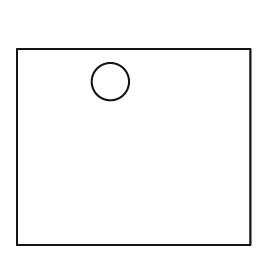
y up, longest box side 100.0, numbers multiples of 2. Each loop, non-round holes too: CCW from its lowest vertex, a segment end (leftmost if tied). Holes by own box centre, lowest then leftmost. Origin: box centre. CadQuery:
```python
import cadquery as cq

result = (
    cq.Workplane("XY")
    .moveTo(-50.0, -42.0)
    .lineTo(50.0, -42.0)
    .lineTo(50.0, 42.0)
    .lineTo(-50.0, 42.0)
    .close()
    .moveTo(-10.0, 28.0)
    .circle(8.0)
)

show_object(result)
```